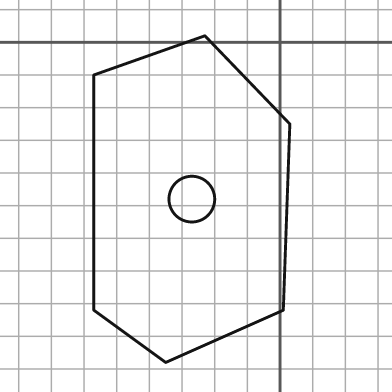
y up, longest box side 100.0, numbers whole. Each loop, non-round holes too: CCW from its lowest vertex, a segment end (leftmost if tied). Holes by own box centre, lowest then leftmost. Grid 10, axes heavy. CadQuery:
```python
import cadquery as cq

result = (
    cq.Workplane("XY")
    .moveTo(-35.0, -98.0)
    .lineTo(1.0, -82.0)
    .lineTo(3.0, -25.0)
    .lineTo(-23.0, 2.0)
    .lineTo(-57.0, -10.0)
    .lineTo(-57.0, -82.0)
    .close()
    .moveTo(-27.0, -48.0)
    .circle(7.0)
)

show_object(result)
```